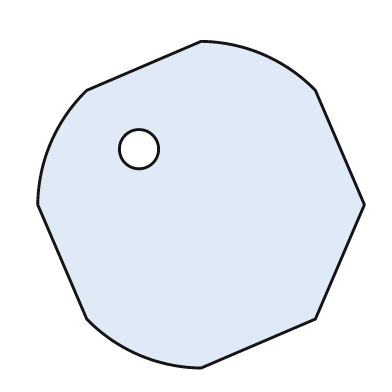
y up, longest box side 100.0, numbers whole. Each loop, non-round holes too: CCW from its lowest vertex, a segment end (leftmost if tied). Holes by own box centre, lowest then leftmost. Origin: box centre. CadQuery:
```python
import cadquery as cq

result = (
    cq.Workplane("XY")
    .moveTo(0.0, -50.0)
    .lineTo(35.0, -35.0)
    .lineTo(50.0, 0.0)
    .lineTo(35.0, 35.0)
    .threePointArc((19.0, 46.0), (0.0, 50.0))
    .lineTo(-35.0, 35.0)
    .threePointArc((-46.0, 19.0), (-50.0, 0.0))
    .lineTo(-35.0, -35.0)
    .threePointArc((-19.0, -46.0), (0.0, -50.0))
    .close()
    .moveTo(-19.0, 17.0)
    .circle(6.0)
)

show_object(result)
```